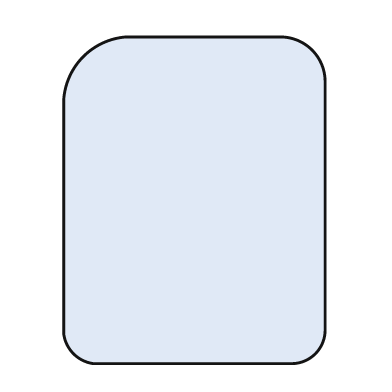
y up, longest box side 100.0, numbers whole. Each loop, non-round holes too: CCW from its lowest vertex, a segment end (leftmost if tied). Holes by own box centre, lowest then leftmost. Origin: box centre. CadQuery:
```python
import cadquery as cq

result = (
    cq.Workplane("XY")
    .moveTo(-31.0, -50.0)
    .lineTo(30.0, -50.0)
    .threePointArc((37.0, -47.0), (40.0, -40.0))
    .lineTo(40.0, 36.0)
    .threePointArc((36.0, 46.0), (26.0, 50.0))
    .lineTo(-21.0, 50.0)
    .threePointArc((-34.0, 44.0), (-40.0, 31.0))
    .lineTo(-40.0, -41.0)
    .threePointArc((-37.0, -47.0), (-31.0, -50.0))
    .close()
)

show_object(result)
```